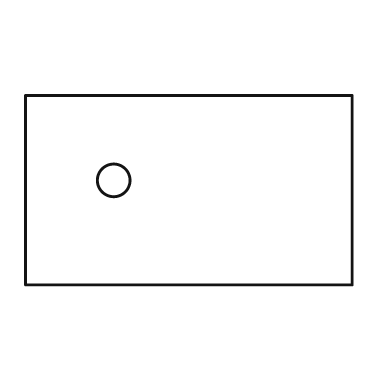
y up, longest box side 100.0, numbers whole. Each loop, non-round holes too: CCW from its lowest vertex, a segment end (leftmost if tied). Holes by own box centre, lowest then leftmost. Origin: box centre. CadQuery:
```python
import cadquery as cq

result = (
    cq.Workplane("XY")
    .moveTo(-50.0, -29.0)
    .lineTo(50.0, -29.0)
    .lineTo(50.0, 29.0)
    .lineTo(-50.0, 29.0)
    .close()
    .moveTo(-23.0, 3.0)
    .circle(5.0)
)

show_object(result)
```